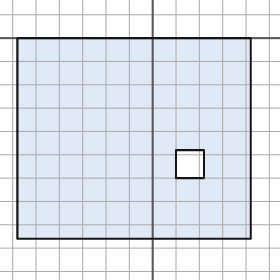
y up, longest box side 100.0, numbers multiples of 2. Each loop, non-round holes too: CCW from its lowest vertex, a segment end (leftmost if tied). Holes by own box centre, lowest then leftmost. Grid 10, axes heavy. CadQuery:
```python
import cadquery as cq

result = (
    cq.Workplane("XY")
    .moveTo(-58.0, -86.0)
    .lineTo(42.0, -86.0)
    .lineTo(42.0, 0.0)
    .lineTo(-58.0, 0.0)
    .close()
    .moveTo(10.0, -60.0)
    .lineTo(22.0, -60.0)
    .lineTo(22.0, -48.0)
    .lineTo(10.0, -48.0)
    .close()
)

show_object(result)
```